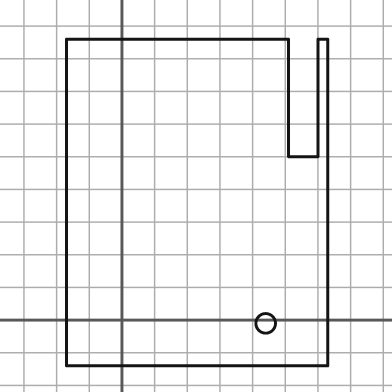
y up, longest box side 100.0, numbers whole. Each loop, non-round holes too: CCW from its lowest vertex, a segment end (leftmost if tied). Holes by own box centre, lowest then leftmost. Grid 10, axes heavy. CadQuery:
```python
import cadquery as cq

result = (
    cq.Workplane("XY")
    .moveTo(-17.0, -14.0)
    .lineTo(63.0, -14.0)
    .lineTo(63.0, 86.0)
    .lineTo(60.0, 86.0)
    .lineTo(60.0, 50.0)
    .lineTo(51.0, 50.0)
    .lineTo(51.0, 86.0)
    .lineTo(-17.0, 86.0)
    .close()
    .moveTo(44.0, -1.0)
    .circle(3.0)
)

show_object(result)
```